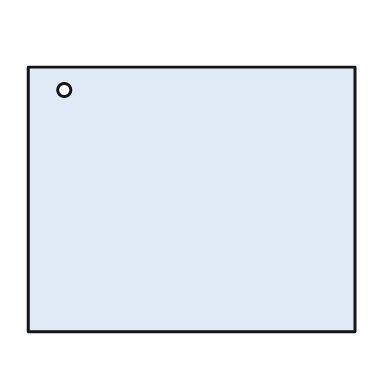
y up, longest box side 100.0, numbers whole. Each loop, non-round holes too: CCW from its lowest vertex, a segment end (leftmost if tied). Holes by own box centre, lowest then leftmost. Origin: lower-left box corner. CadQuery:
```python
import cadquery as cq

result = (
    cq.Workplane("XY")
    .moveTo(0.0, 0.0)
    .lineTo(100.0, 0.0)
    .lineTo(100.0, 81.0)
    .lineTo(0.0, 81.0)
    .close()
    .moveTo(11.0, 74.0)
    .circle(2.0)
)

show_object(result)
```